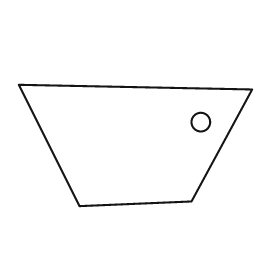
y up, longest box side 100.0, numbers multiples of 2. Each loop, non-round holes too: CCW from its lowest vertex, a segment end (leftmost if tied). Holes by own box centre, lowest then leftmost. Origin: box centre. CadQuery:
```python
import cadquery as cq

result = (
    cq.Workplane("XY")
    .moveTo(-24.0, -26.0)
    .lineTo(24.0, -24.0)
    .lineTo(50.0, 24.0)
    .lineTo(-50.0, 26.0)
    .close()
    .moveTo(28.0, 10.0)
    .circle(4.0)
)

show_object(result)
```